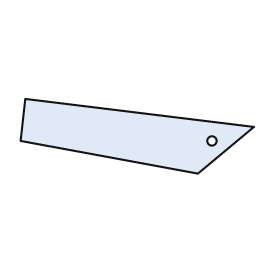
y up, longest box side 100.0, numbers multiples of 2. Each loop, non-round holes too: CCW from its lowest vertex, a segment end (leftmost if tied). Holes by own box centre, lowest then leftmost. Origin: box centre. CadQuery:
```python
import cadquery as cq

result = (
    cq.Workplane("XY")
    .moveTo(26.0, -16.0)
    .lineTo(50.0, 4.0)
    .lineTo(-48.0, 16.0)
    .lineTo(-50.0, -2.0)
    .close()
    .moveTo(32.0, -2.0)
    .circle(2.0)
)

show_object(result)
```